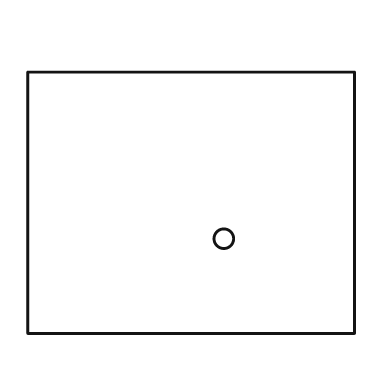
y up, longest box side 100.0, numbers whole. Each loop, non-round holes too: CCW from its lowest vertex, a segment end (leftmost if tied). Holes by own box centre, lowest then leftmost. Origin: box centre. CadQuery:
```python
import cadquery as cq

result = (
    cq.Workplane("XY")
    .moveTo(-50.0, -40.0)
    .lineTo(50.0, -40.0)
    .lineTo(50.0, 40.0)
    .lineTo(-50.0, 40.0)
    .close()
    .moveTo(10.0, -11.0)
    .circle(3.0)
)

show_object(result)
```